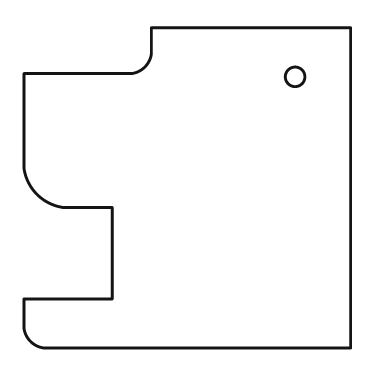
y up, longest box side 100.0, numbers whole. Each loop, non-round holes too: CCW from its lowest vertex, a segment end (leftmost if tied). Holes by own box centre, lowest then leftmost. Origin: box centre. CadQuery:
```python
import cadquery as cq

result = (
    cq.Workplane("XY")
    .moveTo(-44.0, -49.0)
    .lineTo(50.0, -49.0)
    .lineTo(50.0, 49.0)
    .lineTo(-11.0, 49.0)
    .lineTo(-11.0, 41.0)
    .threePointArc((-13.0, 37.0), (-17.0, 35.0))
    .lineTo(-50.0, 35.0)
    .lineTo(-50.0, 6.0)
    .threePointArc((-46.0, -2.0), (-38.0, -6.0))
    .lineTo(-23.0, -6.0)
    .lineTo(-23.0, -34.0)
    .lineTo(-50.0, -34.0)
    .lineTo(-50.0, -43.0)
    .threePointArc((-48.0, -47.0), (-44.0, -49.0))
    .close()
    .moveTo(33.0, 34.0)
    .circle(3.0)
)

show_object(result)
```